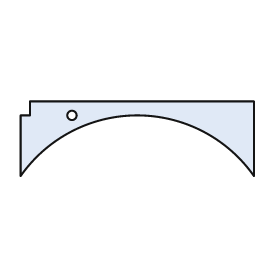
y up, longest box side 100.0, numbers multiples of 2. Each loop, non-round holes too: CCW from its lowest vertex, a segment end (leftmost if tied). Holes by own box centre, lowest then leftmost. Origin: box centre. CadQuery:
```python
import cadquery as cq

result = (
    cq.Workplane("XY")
    .moveTo(-50.0, -16.0)
    .threePointArc((0.0, 10.0), (50.0, -16.0))
    .lineTo(50.0, 16.0)
    .lineTo(-46.0, 16.0)
    .lineTo(-46.0, 10.0)
    .lineTo(-50.0, 10.0)
    .close()
    .moveTo(-28.0, 10.0)
    .circle(2.0)
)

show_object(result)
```